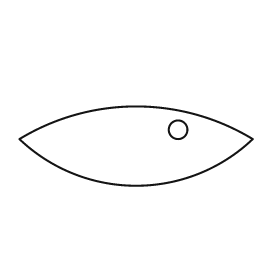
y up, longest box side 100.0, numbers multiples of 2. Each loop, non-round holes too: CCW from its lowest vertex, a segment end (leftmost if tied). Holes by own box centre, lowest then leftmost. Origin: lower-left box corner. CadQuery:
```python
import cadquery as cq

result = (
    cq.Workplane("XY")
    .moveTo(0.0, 20.0)
    .threePointArc((50.0, 0.0), (100.0, 20.0))
    .threePointArc((50.0, 34.0), (0.0, 20.0))
    .close()
    .moveTo(68.0, 24.0)
    .circle(4.0)
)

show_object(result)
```